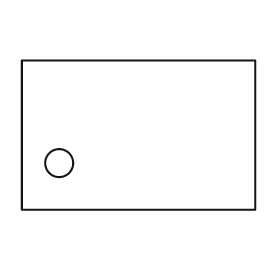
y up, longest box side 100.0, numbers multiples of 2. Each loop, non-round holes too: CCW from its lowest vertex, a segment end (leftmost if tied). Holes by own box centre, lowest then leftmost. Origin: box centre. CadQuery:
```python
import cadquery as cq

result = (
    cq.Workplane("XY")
    .moveTo(-50.0, -32.0)
    .lineTo(50.0, -32.0)
    .lineTo(50.0, 32.0)
    .lineTo(-50.0, 32.0)
    .close()
    .moveTo(-34.0, -12.0)
    .circle(6.0)
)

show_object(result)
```